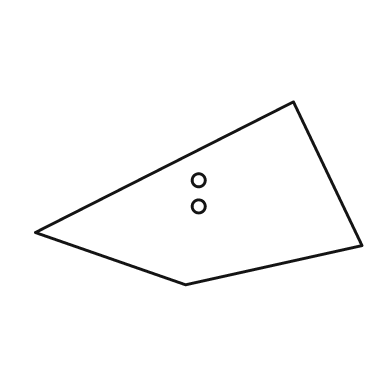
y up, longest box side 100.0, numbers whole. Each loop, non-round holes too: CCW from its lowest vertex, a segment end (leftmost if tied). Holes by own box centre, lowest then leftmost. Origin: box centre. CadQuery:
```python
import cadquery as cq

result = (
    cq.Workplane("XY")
    .moveTo(-4.0, -28.0)
    .lineTo(50.0, -16.0)
    .lineTo(29.0, 28.0)
    .lineTo(-50.0, -12.0)
    .close()
    .moveTo(0.0, -4.0)
    .circle(2.0)
    .moveTo(0.0, 4.0)
    .circle(2.0)
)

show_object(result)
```